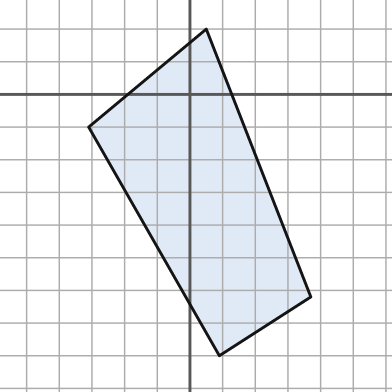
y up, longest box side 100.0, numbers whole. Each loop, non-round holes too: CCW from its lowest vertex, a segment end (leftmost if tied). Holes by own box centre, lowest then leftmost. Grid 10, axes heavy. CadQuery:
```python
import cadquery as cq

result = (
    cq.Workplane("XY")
    .moveTo(9.0, -80.0)
    .lineTo(37.0, -62.0)
    .lineTo(5.0, 20.0)
    .lineTo(-31.0, -10.0)
    .close()
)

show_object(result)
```